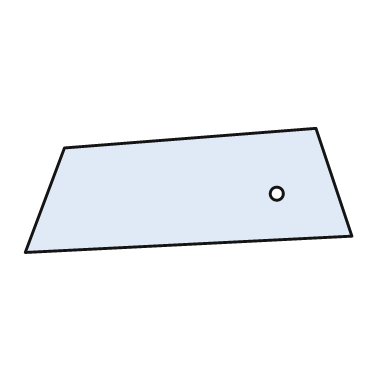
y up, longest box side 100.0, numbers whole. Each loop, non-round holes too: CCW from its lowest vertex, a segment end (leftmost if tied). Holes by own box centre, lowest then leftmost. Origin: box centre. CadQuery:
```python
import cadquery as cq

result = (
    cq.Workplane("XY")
    .moveTo(-50.0, -19.0)
    .lineTo(50.0, -14.0)
    .lineTo(39.0, 19.0)
    .lineTo(-38.0, 13.0)
    .close()
    .moveTo(27.0, -1.0)
    .circle(2.0)
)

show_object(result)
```